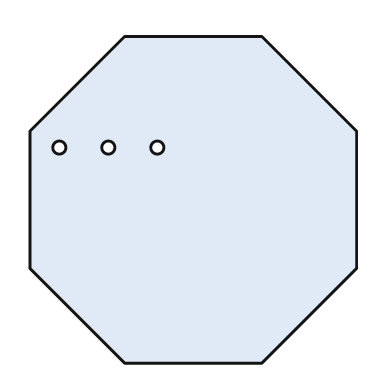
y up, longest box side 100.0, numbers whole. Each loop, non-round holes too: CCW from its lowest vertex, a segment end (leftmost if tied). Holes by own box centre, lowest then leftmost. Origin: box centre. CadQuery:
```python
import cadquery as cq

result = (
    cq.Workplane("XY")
    .moveTo(-21.0, -50.0)
    .lineTo(21.0, -50.0)
    .lineTo(50.0, -21.0)
    .lineTo(50.0, 21.0)
    .lineTo(21.0, 50.0)
    .lineTo(-21.0, 50.0)
    .lineTo(-50.0, 21.0)
    .lineTo(-50.0, -21.0)
    .close()
    .moveTo(-41.0, 16.0)
    .circle(2.0)
    .moveTo(-26.0, 16.0)
    .circle(2.0)
    .moveTo(-11.0, 16.0)
    .circle(2.0)
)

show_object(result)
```